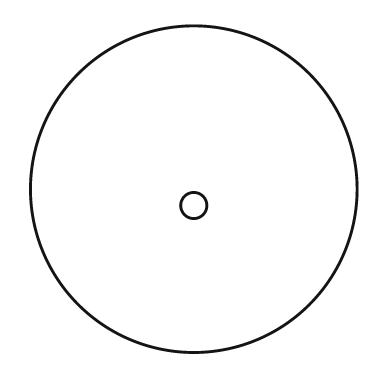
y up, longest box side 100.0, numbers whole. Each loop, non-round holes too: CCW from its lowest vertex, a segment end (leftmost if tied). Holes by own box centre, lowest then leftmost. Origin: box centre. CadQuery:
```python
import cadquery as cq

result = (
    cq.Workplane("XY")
    .moveTo(0.0, 0.0)
    .circle(50.0)
    .moveTo(0.0, -5.0)
    .circle(4.0)
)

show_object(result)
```